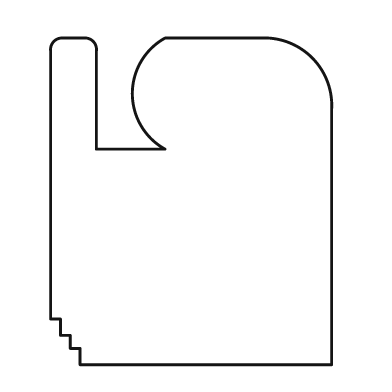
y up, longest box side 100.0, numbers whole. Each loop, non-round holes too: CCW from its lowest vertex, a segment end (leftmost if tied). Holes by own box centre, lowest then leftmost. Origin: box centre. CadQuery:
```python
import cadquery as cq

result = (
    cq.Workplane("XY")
    .moveTo(-34.0, -50.0)
    .lineTo(43.0, -50.0)
    .lineTo(43.0, 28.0)
    .threePointArc((37.0, 44.0), (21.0, 50.0))
    .lineTo(-8.0, 50.0)
    .threePointArc((-18.0, 33.0), (-8.0, 16.0))
    .lineTo(-29.0, 16.0)
    .lineTo(-29.0, 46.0)
    .threePointArc((-30.0, 49.0), (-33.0, 50.0))
    .lineTo(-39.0, 50.0)
    .threePointArc((-42.0, 49.0), (-43.0, 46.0))
    .lineTo(-43.0, -36.0)
    .lineTo(-40.0, -36.0)
    .lineTo(-40.0, -41.0)
    .lineTo(-37.0, -41.0)
    .lineTo(-37.0, -45.0)
    .lineTo(-34.0, -45.0)
    .close()
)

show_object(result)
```